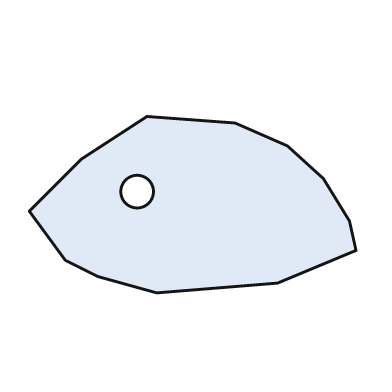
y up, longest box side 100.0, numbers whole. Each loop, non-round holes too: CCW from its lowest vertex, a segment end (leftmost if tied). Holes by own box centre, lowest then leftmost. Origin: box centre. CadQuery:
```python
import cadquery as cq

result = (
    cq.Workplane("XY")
    .moveTo(-11.0, -27.0)
    .lineTo(26.0, -24.0)
    .lineTo(50.0, -14.0)
    .lineTo(48.0, -5.0)
    .lineTo(40.0, 8.0)
    .lineTo(29.0, 18.0)
    .lineTo(13.0, 25.0)
    .lineTo(-14.0, 27.0)
    .lineTo(-34.0, 14.0)
    .lineTo(-50.0, -2.0)
    .lineTo(-39.0, -17.0)
    .lineTo(-29.0, -22.0)
    .close()
    .moveTo(-17.0, 4.0)
    .circle(5.0)
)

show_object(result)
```